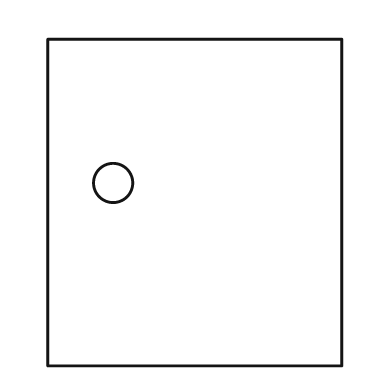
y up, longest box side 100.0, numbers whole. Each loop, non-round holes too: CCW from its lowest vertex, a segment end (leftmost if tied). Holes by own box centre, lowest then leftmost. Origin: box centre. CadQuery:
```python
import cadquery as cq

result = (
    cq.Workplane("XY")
    .moveTo(-45.0, -50.0)
    .lineTo(45.0, -50.0)
    .lineTo(45.0, 50.0)
    .lineTo(-45.0, 50.0)
    .close()
    .moveTo(-25.0, 6.0)
    .circle(6.0)
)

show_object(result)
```